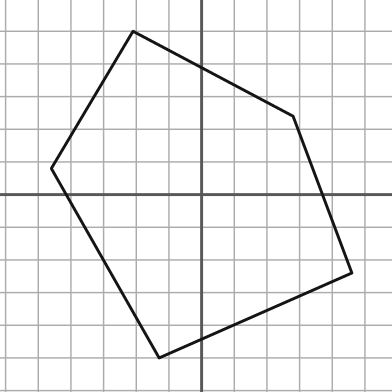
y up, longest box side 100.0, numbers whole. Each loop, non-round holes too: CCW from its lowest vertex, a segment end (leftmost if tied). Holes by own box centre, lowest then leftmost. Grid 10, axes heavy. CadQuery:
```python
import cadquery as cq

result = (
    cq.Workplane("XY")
    .moveTo(-13.0, -50.0)
    .lineTo(46.0, -24.0)
    .lineTo(28.0, 24.0)
    .lineTo(-21.0, 50.0)
    .lineTo(-46.0, 8.0)
    .close()
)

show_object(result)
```